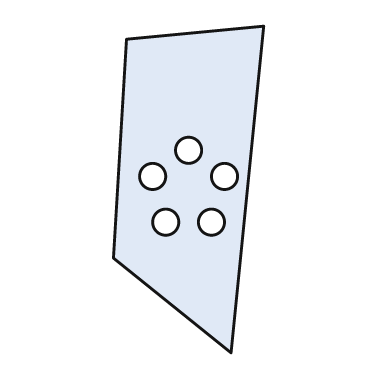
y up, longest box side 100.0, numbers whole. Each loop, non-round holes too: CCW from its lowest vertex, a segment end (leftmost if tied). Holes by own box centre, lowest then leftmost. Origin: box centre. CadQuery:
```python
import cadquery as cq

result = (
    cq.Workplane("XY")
    .moveTo(13.0, -50.0)
    .lineTo(23.0, 50.0)
    .lineTo(-19.0, 46.0)
    .lineTo(-23.0, -21.0)
    .close()
    .moveTo(-7.0, -10.0)
    .circle(4.0)
    .moveTo(7.0, -10.0)
    .circle(4.0)
    .moveTo(-11.0, 4.0)
    .circle(4.0)
    .moveTo(11.0, 4.0)
    .circle(4.0)
    .moveTo(0.0, 12.0)
    .circle(4.0)
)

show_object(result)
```